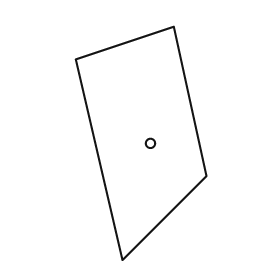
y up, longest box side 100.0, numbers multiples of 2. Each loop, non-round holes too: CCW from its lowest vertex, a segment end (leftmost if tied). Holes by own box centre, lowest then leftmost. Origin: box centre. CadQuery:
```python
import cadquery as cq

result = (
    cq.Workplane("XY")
    .moveTo(-8.0, -50.0)
    .lineTo(28.0, -14.0)
    .lineTo(14.0, 50.0)
    .lineTo(-28.0, 36.0)
    .close()
    .moveTo(4.0, 0.0)
    .circle(2.0)
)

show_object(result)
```